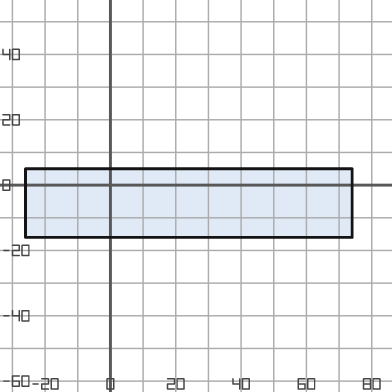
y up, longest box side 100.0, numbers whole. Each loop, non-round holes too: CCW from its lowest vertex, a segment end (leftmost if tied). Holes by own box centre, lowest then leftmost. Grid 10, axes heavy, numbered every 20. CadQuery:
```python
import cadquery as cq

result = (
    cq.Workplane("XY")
    .moveTo(-26.0, -16.0)
    .lineTo(74.0, -16.0)
    .lineTo(74.0, 5.0)
    .lineTo(-26.0, 5.0)
    .close()
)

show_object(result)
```